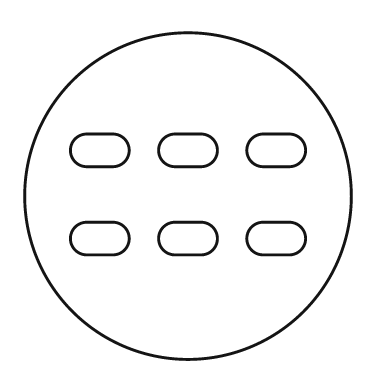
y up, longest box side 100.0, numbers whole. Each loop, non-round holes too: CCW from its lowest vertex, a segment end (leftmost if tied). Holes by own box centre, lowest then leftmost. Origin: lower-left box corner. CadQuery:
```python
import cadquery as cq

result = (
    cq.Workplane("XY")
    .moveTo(50.0, 50.0)
    .circle(50.0)
    .moveTo(19.0, 32.0)
    .lineTo(27.0, 32.0)
    .threePointArc((32.0, 37.0), (27.0, 42.0))
    .lineTo(19.0, 42.0)
    .threePointArc((14.0, 37.0), (19.0, 32.0))
    .close()
    .moveTo(46.0, 32.0)
    .lineTo(54.0, 32.0)
    .threePointArc((59.0, 37.0), (54.0, 42.0))
    .lineTo(46.0, 42.0)
    .threePointArc((41.0, 37.0), (46.0, 32.0))
    .close()
    .moveTo(73.0, 32.0)
    .lineTo(81.0, 32.0)
    .threePointArc((86.0, 37.0), (81.0, 42.0))
    .lineTo(73.0, 42.0)
    .threePointArc((68.0, 37.0), (73.0, 32.0))
    .close()
    .moveTo(19.0, 59.0)
    .lineTo(27.0, 59.0)
    .threePointArc((32.0, 64.0), (27.0, 69.0))
    .lineTo(19.0, 69.0)
    .threePointArc((14.0, 64.0), (19.0, 59.0))
    .close()
    .moveTo(46.0, 59.0)
    .lineTo(54.0, 59.0)
    .threePointArc((59.0, 64.0), (54.0, 69.0))
    .lineTo(46.0, 69.0)
    .threePointArc((41.0, 64.0), (46.0, 59.0))
    .close()
    .moveTo(73.0, 59.0)
    .lineTo(81.0, 59.0)
    .threePointArc((86.0, 64.0), (81.0, 69.0))
    .lineTo(73.0, 69.0)
    .threePointArc((68.0, 64.0), (73.0, 59.0))
    .close()
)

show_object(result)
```